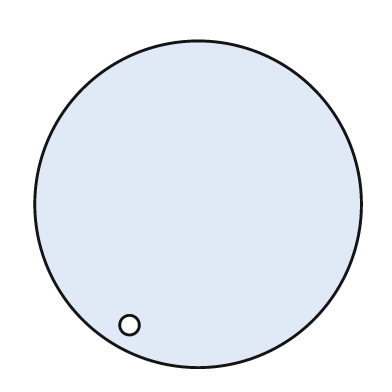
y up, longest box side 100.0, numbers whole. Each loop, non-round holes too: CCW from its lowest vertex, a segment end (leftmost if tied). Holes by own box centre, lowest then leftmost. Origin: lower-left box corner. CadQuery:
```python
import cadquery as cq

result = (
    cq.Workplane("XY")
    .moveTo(50.0, 50.0)
    .circle(50.0)
    .moveTo(29.0, 13.0)
    .circle(3.0)
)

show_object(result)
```